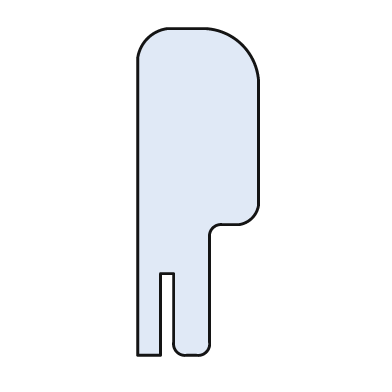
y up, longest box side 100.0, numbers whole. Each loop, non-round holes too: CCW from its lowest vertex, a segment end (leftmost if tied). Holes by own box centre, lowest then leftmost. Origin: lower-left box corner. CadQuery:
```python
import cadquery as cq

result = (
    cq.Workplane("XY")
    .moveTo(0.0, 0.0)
    .lineTo(7.0, 0.0)
    .lineTo(7.0, 25.0)
    .lineTo(11.0, 25.0)
    .lineTo(11.0, 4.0)
    .threePointArc((12.0, 1.0), (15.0, 0.0))
    .lineTo(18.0, 0.0)
    .threePointArc((21.0, 1.0), (22.0, 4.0))
    .lineTo(22.0, 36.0)
    .threePointArc((23.0, 39.0), (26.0, 40.0))
    .lineTo(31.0, 40.0)
    .threePointArc((35.0, 42.0), (37.0, 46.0))
    .lineTo(37.0, 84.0)
    .threePointArc((32.0, 95.0), (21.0, 100.0))
    .lineTo(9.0, 100.0)
    .threePointArc((3.0, 97.0), (0.0, 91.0))
    .close()
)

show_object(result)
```